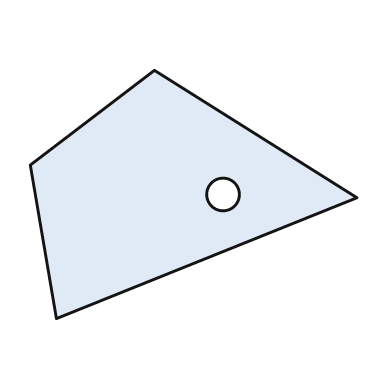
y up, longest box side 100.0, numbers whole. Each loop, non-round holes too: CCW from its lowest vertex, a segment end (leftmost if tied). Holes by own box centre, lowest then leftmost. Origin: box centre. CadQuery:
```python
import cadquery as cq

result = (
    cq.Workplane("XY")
    .moveTo(-42.0, -38.0)
    .lineTo(50.0, -1.0)
    .lineTo(-12.0, 38.0)
    .lineTo(-50.0, 9.0)
    .close()
    .moveTo(9.0, 0.0)
    .circle(5.0)
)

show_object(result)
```